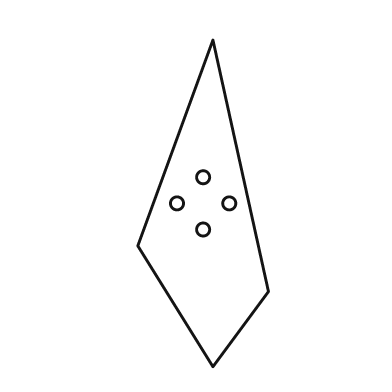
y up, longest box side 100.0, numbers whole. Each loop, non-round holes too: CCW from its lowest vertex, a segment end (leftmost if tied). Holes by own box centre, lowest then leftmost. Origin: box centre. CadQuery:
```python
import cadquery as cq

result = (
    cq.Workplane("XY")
    .moveTo(3.0, -50.0)
    .lineTo(20.0, -27.0)
    .lineTo(3.0, 50.0)
    .lineTo(-20.0, -13.0)
    .close()
    .moveTo(0.0, -8.0)
    .circle(2.0)
    .moveTo(-8.0, 0.0)
    .circle(2.0)
    .moveTo(8.0, 0.0)
    .circle(2.0)
    .moveTo(0.0, 8.0)
    .circle(2.0)
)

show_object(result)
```